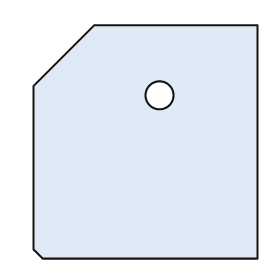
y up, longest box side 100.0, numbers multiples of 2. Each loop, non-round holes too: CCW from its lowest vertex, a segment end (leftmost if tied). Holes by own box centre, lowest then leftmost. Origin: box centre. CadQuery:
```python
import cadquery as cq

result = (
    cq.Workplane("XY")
    .moveTo(-44.0, -50.0)
    .lineTo(48.0, -50.0)
    .lineTo(48.0, 50.0)
    .lineTo(-22.0, 50.0)
    .lineTo(-48.0, 24.0)
    .lineTo(-48.0, -46.0)
    .close()
    .moveTo(6.0, 20.0)
    .circle(6.0)
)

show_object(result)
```